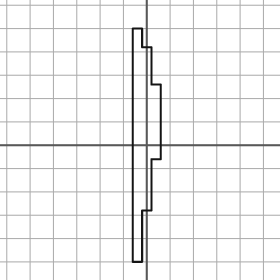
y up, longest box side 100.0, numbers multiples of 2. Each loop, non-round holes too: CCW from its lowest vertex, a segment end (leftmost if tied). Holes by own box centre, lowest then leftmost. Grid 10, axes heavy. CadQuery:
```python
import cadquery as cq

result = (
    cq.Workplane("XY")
    .moveTo(-6.0, -50.0)
    .lineTo(-2.0, -50.0)
    .lineTo(-2.0, -28.0)
    .lineTo(2.0, -28.0)
    .lineTo(2.0, -6.0)
    .lineTo(6.0, -6.0)
    .lineTo(6.0, 26.0)
    .lineTo(2.0, 26.0)
    .lineTo(2.0, 42.0)
    .lineTo(-2.0, 42.0)
    .lineTo(-2.0, 50.0)
    .lineTo(-6.0, 50.0)
    .close()
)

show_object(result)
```